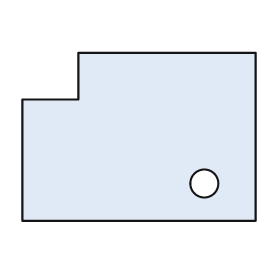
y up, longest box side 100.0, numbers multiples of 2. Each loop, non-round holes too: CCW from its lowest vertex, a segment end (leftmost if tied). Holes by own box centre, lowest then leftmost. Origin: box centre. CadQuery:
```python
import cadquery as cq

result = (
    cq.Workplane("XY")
    .moveTo(-50.0, -36.0)
    .lineTo(50.0, -36.0)
    .lineTo(50.0, 36.0)
    .lineTo(-26.0, 36.0)
    .lineTo(-26.0, 16.0)
    .lineTo(-50.0, 16.0)
    .close()
    .moveTo(28.0, -20.0)
    .circle(6.0)
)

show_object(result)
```